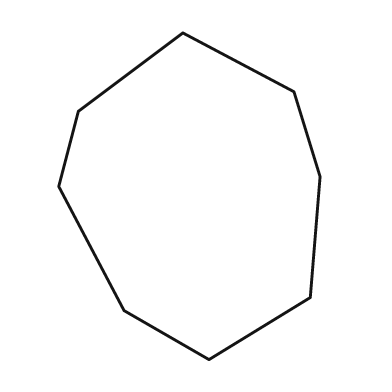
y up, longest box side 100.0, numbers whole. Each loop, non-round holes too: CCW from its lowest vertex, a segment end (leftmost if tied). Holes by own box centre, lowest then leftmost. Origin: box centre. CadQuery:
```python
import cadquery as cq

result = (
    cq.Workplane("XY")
    .moveTo(6.0, -50.0)
    .lineTo(37.0, -31.0)
    .lineTo(40.0, 6.0)
    .lineTo(32.0, 32.0)
    .lineTo(-2.0, 50.0)
    .lineTo(-34.0, 26.0)
    .lineTo(-40.0, 3.0)
    .lineTo(-20.0, -35.0)
    .close()
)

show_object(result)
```